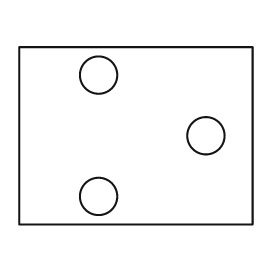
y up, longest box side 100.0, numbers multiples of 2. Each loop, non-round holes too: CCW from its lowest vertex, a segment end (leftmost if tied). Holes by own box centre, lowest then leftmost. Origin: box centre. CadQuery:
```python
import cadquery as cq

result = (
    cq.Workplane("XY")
    .moveTo(-50.0, -38.0)
    .lineTo(50.0, -38.0)
    .lineTo(50.0, 38.0)
    .lineTo(-50.0, 38.0)
    .close()
    .moveTo(-16.0, -26.0)
    .circle(8.0)
    .moveTo(30.0, 0.0)
    .circle(8.0)
    .moveTo(-16.0, 26.0)
    .circle(8.0)
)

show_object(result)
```